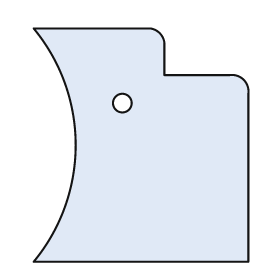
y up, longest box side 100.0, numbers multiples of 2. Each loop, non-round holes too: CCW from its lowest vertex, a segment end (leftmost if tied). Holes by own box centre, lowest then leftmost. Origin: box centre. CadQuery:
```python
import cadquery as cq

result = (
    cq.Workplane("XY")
    .moveTo(-46.0, -50.0)
    .lineTo(46.0, -50.0)
    .lineTo(46.0, 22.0)
    .threePointArc((44.0, 28.0), (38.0, 30.0))
    .lineTo(10.0, 30.0)
    .lineTo(10.0, 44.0)
    .threePointArc((8.0, 48.0), (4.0, 50.0))
    .lineTo(-46.0, 50.0)
    .threePointArc((-28.0, 0.0), (-46.0, -50.0))
    .close()
    .moveTo(-8.0, 18.0)
    .circle(4.0)
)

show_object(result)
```